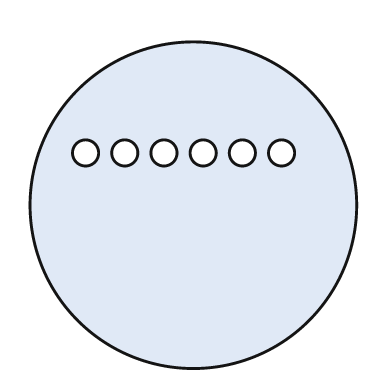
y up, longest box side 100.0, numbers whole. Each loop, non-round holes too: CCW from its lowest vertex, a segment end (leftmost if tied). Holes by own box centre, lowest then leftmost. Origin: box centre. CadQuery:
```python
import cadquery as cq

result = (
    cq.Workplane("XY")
    .moveTo(0.0, 0.0)
    .circle(50.0)
    .moveTo(-33.0, 16.0)
    .circle(4.0)
    .moveTo(-21.0, 16.0)
    .circle(4.0)
    .moveTo(-9.0, 16.0)
    .circle(4.0)
    .moveTo(3.0, 16.0)
    .circle(4.0)
    .moveTo(15.0, 16.0)
    .circle(4.0)
    .moveTo(27.0, 16.0)
    .circle(4.0)
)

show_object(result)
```